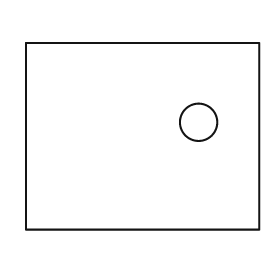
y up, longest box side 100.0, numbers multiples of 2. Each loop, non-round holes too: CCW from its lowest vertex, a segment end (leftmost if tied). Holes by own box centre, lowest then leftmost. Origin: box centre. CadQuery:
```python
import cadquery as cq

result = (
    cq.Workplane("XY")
    .moveTo(-50.0, -40.0)
    .lineTo(50.0, -40.0)
    .lineTo(50.0, 40.0)
    .lineTo(-50.0, 40.0)
    .close()
    .moveTo(24.0, 6.0)
    .circle(8.0)
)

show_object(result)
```